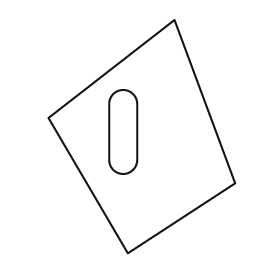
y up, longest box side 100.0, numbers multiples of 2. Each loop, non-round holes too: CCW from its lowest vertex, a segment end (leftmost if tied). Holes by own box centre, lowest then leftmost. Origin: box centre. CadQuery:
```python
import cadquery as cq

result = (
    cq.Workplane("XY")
    .moveTo(-6.0, -50.0)
    .lineTo(40.0, -20.0)
    .lineTo(14.0, 50.0)
    .lineTo(-40.0, 8.0)
    .close()
    .moveTo(-14.0, -10.0)
    .threePointArc((-8.0, -16.0), (-2.0, -10.0))
    .lineTo(-2.0, 14.0)
    .threePointArc((-8.0, 20.0), (-14.0, 14.0))
    .close()
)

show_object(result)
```